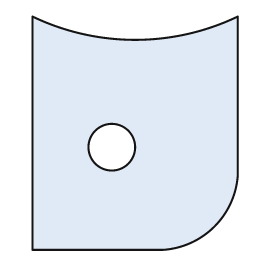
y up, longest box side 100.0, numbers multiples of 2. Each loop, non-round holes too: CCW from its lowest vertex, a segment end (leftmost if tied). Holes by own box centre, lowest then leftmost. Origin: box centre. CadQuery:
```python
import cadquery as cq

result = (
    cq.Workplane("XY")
    .moveTo(-44.0, -50.0)
    .lineTo(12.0, -50.0)
    .threePointArc((34.0, -40.0), (44.0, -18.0))
    .lineTo(44.0, 50.0)
    .threePointArc((0.0, 40.0), (-44.0, 50.0))
    .close()
    .moveTo(-10.0, -6.0)
    .circle(10.0)
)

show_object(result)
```